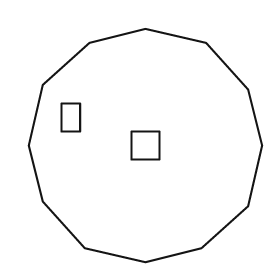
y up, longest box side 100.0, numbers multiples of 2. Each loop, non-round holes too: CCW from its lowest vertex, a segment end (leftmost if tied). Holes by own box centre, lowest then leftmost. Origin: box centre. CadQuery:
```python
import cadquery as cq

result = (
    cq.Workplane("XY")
    .moveTo(0.0, -50.0)
    .lineTo(24.0, -44.0)
    .lineTo(44.0, -26.0)
    .lineTo(50.0, 0.0)
    .lineTo(44.0, 24.0)
    .lineTo(26.0, 44.0)
    .lineTo(0.0, 50.0)
    .lineTo(-24.0, 44.0)
    .lineTo(-44.0, 26.0)
    .lineTo(-50.0, 0.0)
    .lineTo(-44.0, -24.0)
    .lineTo(-26.0, -44.0)
    .close()
    .moveTo(-6.0, -6.0)
    .lineTo(6.0, -6.0)
    .lineTo(6.0, 6.0)
    .lineTo(-6.0, 6.0)
    .close()
    .moveTo(-36.0, 6.0)
    .lineTo(-28.0, 6.0)
    .lineTo(-28.0, 18.0)
    .lineTo(-36.0, 18.0)
    .close()
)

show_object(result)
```